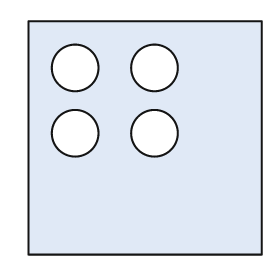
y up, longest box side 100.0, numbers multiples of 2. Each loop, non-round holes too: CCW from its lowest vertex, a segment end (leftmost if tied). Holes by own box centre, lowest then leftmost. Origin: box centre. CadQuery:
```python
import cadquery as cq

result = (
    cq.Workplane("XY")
    .moveTo(-50.0, -50.0)
    .lineTo(50.0, -50.0)
    .lineTo(50.0, 50.0)
    .lineTo(-50.0, 50.0)
    .close()
    .moveTo(-30.0, 2.0)
    .circle(10.0)
    .moveTo(4.0, 2.0)
    .circle(10.0)
    .moveTo(-30.0, 30.0)
    .circle(10.0)
    .moveTo(4.0, 30.0)
    .circle(10.0)
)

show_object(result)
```